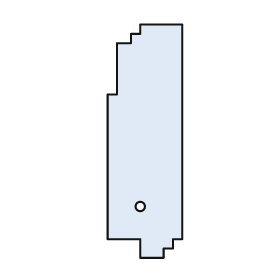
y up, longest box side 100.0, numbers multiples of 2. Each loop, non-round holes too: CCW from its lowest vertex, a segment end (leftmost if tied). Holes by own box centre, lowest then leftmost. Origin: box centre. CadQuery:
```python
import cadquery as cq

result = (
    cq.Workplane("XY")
    .moveTo(-2.0, -50.0)
    .lineTo(8.0, -50.0)
    .lineTo(8.0, -46.0)
    .lineTo(12.0, -46.0)
    .lineTo(12.0, -42.0)
    .lineTo(16.0, -42.0)
    .lineTo(16.0, 50.0)
    .lineTo(-2.0, 50.0)
    .lineTo(-2.0, 46.0)
    .lineTo(-6.0, 46.0)
    .lineTo(-6.0, 42.0)
    .lineTo(-12.0, 42.0)
    .lineTo(-12.0, 20.0)
    .lineTo(-16.0, 20.0)
    .lineTo(-16.0, -42.0)
    .lineTo(-2.0, -42.0)
    .close()
    .moveTo(-2.0, -28.0)
    .circle(2.0)
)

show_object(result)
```